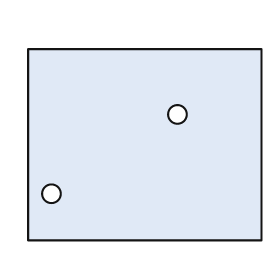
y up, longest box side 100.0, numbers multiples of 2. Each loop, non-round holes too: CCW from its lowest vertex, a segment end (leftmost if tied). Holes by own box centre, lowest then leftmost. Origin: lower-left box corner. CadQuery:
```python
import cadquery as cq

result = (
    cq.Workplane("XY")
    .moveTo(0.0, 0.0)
    .lineTo(100.0, 0.0)
    .lineTo(100.0, 82.0)
    .lineTo(0.0, 82.0)
    .close()
    .moveTo(10.0, 20.0)
    .circle(4.0)
    .moveTo(64.0, 54.0)
    .circle(4.0)
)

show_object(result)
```